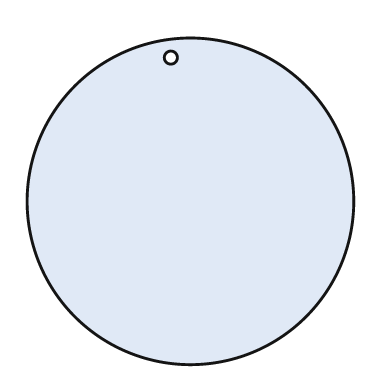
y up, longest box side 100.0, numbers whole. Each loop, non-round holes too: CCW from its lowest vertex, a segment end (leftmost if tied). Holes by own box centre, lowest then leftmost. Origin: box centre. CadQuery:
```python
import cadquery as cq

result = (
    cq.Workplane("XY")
    .moveTo(0.0, 0.0)
    .circle(50.0)
    .moveTo(-6.0, 44.0)
    .circle(2.0)
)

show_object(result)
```